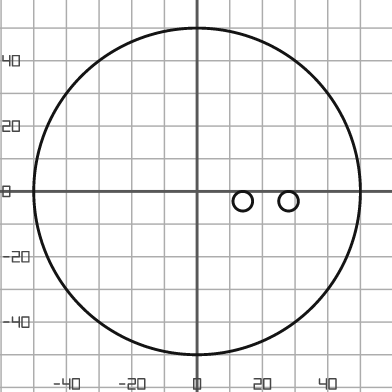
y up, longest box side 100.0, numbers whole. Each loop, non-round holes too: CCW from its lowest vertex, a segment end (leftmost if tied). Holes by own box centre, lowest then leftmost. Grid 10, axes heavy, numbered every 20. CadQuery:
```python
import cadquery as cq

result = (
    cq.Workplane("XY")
    .moveTo(0.0, 0.0)
    .circle(50.0)
    .moveTo(14.0, -3.0)
    .circle(3.0)
    .moveTo(28.0, -3.0)
    .circle(3.0)
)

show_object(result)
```